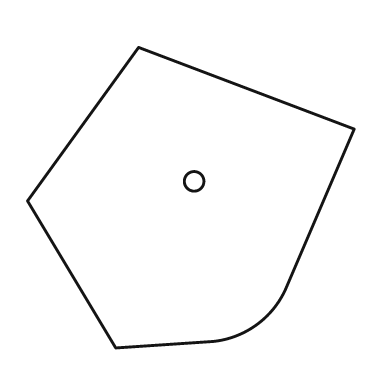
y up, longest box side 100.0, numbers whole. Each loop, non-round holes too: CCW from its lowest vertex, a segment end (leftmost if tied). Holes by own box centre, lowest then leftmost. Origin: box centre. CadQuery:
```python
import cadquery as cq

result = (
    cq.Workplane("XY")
    .moveTo(-23.0, -46.0)
    .lineTo(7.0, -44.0)
    .threePointArc((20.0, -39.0), (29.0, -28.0))
    .lineTo(50.0, 21.0)
    .lineTo(-16.0, 46.0)
    .lineTo(-50.0, -1.0)
    .close()
    .moveTo(1.0, 5.0)
    .circle(3.0)
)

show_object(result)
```